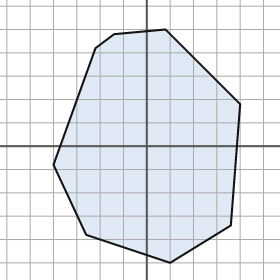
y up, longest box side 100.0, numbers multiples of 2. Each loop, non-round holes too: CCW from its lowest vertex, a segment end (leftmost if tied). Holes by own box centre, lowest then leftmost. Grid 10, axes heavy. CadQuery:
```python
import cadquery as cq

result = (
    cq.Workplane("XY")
    .moveTo(10.0, -50.0)
    .lineTo(36.0, -34.0)
    .lineTo(40.0, 18.0)
    .lineTo(8.0, 50.0)
    .lineTo(-14.0, 48.0)
    .lineTo(-22.0, 42.0)
    .lineTo(-40.0, -8.0)
    .lineTo(-26.0, -38.0)
    .close()
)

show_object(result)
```